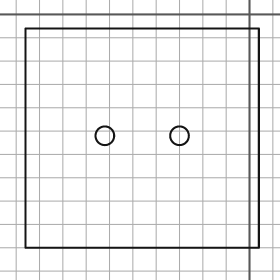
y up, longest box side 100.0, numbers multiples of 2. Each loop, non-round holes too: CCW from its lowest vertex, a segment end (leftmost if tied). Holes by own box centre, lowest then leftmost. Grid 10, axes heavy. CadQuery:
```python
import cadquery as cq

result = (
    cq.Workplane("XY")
    .moveTo(-96.0, -100.0)
    .lineTo(4.0, -100.0)
    .lineTo(4.0, -6.0)
    .lineTo(-96.0, -6.0)
    .close()
    .moveTo(-62.0, -52.0)
    .circle(4.0)
    .moveTo(-30.0, -52.0)
    .circle(4.0)
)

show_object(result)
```